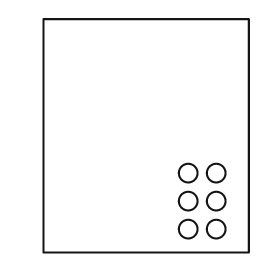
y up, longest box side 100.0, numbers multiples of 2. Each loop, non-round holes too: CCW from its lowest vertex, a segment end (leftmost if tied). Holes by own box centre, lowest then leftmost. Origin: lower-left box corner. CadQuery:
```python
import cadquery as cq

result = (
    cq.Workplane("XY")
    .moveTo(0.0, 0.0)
    .lineTo(88.0, 0.0)
    .lineTo(88.0, 100.0)
    .lineTo(0.0, 100.0)
    .close()
    .moveTo(62.0, 10.0)
    .circle(4.0)
    .moveTo(74.0, 10.0)
    .circle(4.0)
    .moveTo(62.0, 22.0)
    .circle(4.0)
    .moveTo(74.0, 22.0)
    .circle(4.0)
    .moveTo(62.0, 34.0)
    .circle(4.0)
    .moveTo(74.0, 34.0)
    .circle(4.0)
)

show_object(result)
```